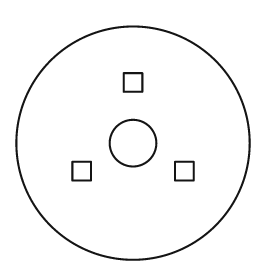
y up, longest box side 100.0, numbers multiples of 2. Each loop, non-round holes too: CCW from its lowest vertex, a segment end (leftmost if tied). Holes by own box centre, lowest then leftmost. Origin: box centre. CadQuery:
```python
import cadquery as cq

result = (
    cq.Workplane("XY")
    .moveTo(0.0, 0.0)
    .circle(50.0)
    .moveTo(-26.0, -16.0)
    .lineTo(-18.0, -16.0)
    .lineTo(-18.0, -8.0)
    .lineTo(-26.0, -8.0)
    .close()
    .moveTo(18.0, -16.0)
    .lineTo(26.0, -16.0)
    .lineTo(26.0, -8.0)
    .lineTo(18.0, -8.0)
    .close()
    .moveTo(0.0, 0.0)
    .circle(10.0)
    .moveTo(-4.0, 22.0)
    .lineTo(4.0, 22.0)
    .lineTo(4.0, 30.0)
    .lineTo(-4.0, 30.0)
    .close()
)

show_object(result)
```